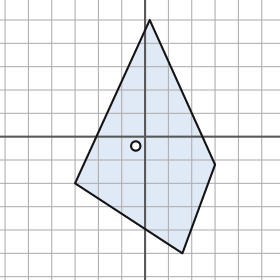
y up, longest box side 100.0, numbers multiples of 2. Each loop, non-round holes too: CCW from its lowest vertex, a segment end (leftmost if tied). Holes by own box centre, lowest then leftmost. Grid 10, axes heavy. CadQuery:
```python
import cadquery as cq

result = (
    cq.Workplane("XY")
    .moveTo(16.0, -50.0)
    .lineTo(30.0, -12.0)
    .lineTo(2.0, 50.0)
    .lineTo(-30.0, -20.0)
    .close()
    .moveTo(-4.0, -4.0)
    .circle(2.0)
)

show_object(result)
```